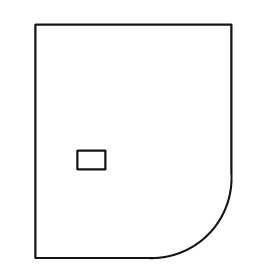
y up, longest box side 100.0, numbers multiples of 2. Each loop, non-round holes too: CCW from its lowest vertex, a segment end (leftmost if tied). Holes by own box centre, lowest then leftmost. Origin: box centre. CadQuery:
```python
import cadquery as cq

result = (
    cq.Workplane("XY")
    .moveTo(-42.0, -50.0)
    .lineTo(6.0, -50.0)
    .threePointArc((32.0, -40.0), (42.0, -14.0))
    .lineTo(42.0, 50.0)
    .lineTo(-42.0, 50.0)
    .close()
    .moveTo(-24.0, -12.0)
    .lineTo(-12.0, -12.0)
    .lineTo(-12.0, -4.0)
    .lineTo(-24.0, -4.0)
    .close()
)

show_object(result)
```